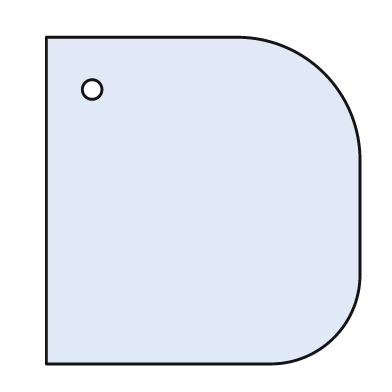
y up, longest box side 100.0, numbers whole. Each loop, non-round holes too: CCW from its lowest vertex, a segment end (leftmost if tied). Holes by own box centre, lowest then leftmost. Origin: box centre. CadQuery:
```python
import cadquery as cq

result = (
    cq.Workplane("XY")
    .moveTo(-48.0, -50.0)
    .lineTo(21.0, -50.0)
    .threePointArc((40.0, -42.0), (48.0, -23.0))
    .lineTo(48.0, 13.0)
    .threePointArc((37.0, 39.0), (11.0, 50.0))
    .lineTo(-48.0, 50.0)
    .close()
    .moveTo(-34.0, 34.0)
    .circle(3.0)
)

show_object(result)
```